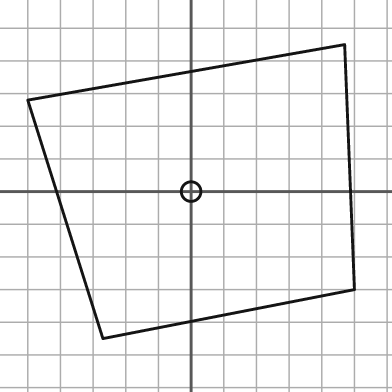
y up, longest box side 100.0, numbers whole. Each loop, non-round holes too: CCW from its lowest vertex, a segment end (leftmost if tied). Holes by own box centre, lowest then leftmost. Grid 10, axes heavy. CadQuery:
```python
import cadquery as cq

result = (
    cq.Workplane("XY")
    .moveTo(-27.0, -45.0)
    .lineTo(50.0, -30.0)
    .lineTo(47.0, 45.0)
    .lineTo(-50.0, 28.0)
    .close()
    .moveTo(0.0, 0.0)
    .circle(3.0)
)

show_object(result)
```